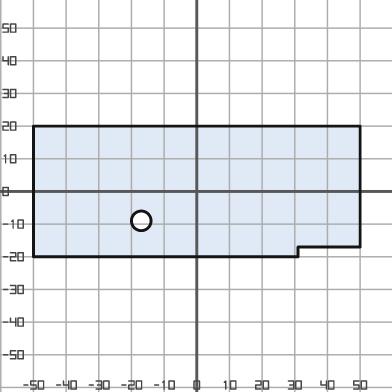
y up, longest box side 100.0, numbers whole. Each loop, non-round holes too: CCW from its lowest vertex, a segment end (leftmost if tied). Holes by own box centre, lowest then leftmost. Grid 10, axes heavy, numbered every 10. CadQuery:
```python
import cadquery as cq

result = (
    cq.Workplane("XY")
    .moveTo(-50.0, -20.0)
    .lineTo(31.0, -20.0)
    .lineTo(31.0, -17.0)
    .lineTo(50.0, -17.0)
    .lineTo(50.0, 20.0)
    .lineTo(-50.0, 20.0)
    .close()
    .moveTo(-17.0, -9.0)
    .circle(3.0)
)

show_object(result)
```